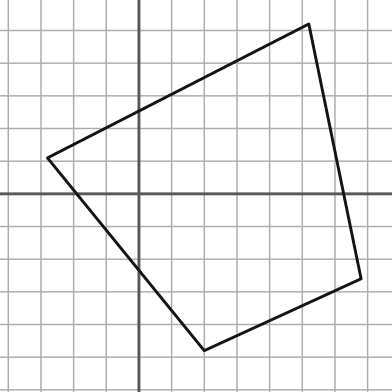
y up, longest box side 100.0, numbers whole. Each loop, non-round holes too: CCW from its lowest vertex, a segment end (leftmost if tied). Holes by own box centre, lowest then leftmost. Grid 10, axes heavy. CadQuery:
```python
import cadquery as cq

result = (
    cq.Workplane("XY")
    .moveTo(20.0, -48.0)
    .lineTo(68.0, -26.0)
    .lineTo(52.0, 52.0)
    .lineTo(-28.0, 11.0)
    .close()
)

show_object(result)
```